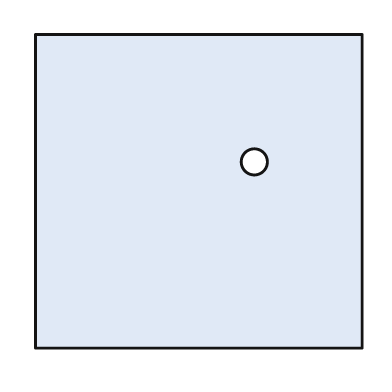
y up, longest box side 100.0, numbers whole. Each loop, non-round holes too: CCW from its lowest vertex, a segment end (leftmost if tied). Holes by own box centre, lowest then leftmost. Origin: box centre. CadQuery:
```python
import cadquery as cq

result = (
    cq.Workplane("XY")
    .moveTo(-50.0, -48.0)
    .lineTo(50.0, -48.0)
    .lineTo(50.0, 48.0)
    .lineTo(-50.0, 48.0)
    .close()
    .moveTo(17.0, 9.0)
    .circle(4.0)
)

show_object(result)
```